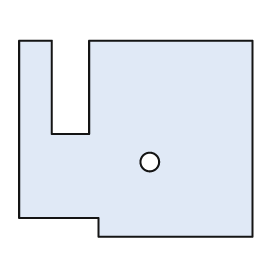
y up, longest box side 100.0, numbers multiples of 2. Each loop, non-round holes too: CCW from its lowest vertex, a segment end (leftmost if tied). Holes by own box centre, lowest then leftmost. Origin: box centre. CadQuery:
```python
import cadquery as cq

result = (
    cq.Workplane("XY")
    .moveTo(-16.0, -42.0)
    .lineTo(50.0, -42.0)
    .lineTo(50.0, 42.0)
    .lineTo(-20.0, 42.0)
    .lineTo(-20.0, 2.0)
    .lineTo(-36.0, 2.0)
    .lineTo(-36.0, 42.0)
    .lineTo(-50.0, 42.0)
    .lineTo(-50.0, -34.0)
    .lineTo(-16.0, -34.0)
    .close()
    .moveTo(6.0, -10.0)
    .circle(4.0)
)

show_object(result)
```